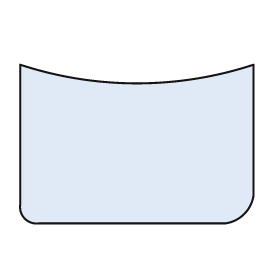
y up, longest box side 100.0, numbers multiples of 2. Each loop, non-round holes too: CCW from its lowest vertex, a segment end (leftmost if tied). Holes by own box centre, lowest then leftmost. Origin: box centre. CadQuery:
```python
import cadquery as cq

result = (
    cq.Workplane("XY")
    .moveTo(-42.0, -34.0)
    .lineTo(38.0, -34.0)
    .threePointArc((46.0, -30.0), (50.0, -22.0))
    .lineTo(50.0, 34.0)
    .threePointArc((0.0, 26.0), (-50.0, 34.0))
    .lineTo(-50.0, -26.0)
    .threePointArc((-48.0, -32.0), (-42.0, -34.0))
    .close()
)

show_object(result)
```